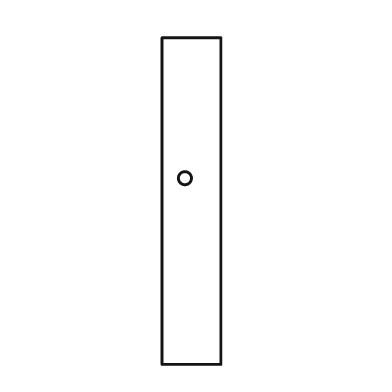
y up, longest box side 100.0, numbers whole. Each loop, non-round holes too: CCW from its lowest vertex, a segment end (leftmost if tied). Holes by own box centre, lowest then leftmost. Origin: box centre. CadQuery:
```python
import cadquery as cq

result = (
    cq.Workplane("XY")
    .moveTo(-9.0, -50.0)
    .lineTo(9.0, -50.0)
    .lineTo(9.0, 50.0)
    .lineTo(-9.0, 50.0)
    .close()
    .moveTo(-2.0, 7.0)
    .circle(2.0)
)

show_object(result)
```